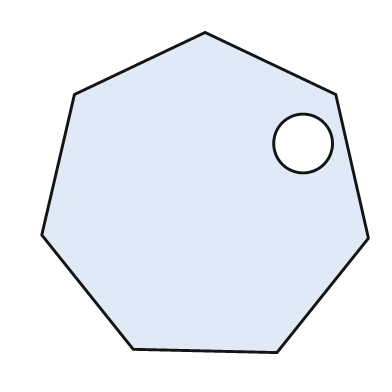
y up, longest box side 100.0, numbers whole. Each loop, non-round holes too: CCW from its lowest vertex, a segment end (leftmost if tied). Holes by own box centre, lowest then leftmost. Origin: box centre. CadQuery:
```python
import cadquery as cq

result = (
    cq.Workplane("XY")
    .moveTo(22.0, -49.0)
    .lineTo(50.0, -14.0)
    .lineTo(40.0, 30.0)
    .lineTo(0.0, 49.0)
    .lineTo(-40.0, 30.0)
    .lineTo(-50.0, -13.0)
    .lineTo(-22.0, -48.0)
    .close()
    .moveTo(30.0, 15.0)
    .circle(9.0)
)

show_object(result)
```